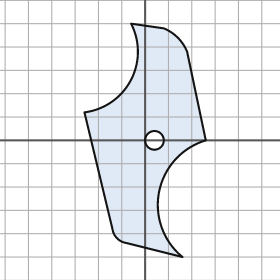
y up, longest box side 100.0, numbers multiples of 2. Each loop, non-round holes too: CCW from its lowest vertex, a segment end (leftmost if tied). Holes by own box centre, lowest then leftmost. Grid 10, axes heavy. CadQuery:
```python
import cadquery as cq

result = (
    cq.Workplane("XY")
    .moveTo(16.0, -50.0)
    .threePointArc((6.0, -22.0), (26.0, 0.0))
    .lineTo(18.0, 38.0)
    .threePointArc((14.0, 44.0), (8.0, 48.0))
    .lineTo(-6.0, 50.0)
    .threePointArc((-6.0, 26.0), (-26.0, 12.0))
    .lineTo(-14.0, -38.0)
    .threePointArc((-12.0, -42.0), (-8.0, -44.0))
    .close()
    .moveTo(4.0, 0.0)
    .circle(4.0)
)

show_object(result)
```